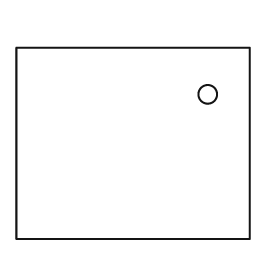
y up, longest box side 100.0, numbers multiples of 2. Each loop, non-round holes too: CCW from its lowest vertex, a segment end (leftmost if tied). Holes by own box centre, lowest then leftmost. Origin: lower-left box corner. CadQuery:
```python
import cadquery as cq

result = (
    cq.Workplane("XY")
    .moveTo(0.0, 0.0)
    .lineTo(100.0, 0.0)
    .lineTo(100.0, 82.0)
    .lineTo(0.0, 82.0)
    .close()
    .moveTo(82.0, 62.0)
    .circle(4.0)
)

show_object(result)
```